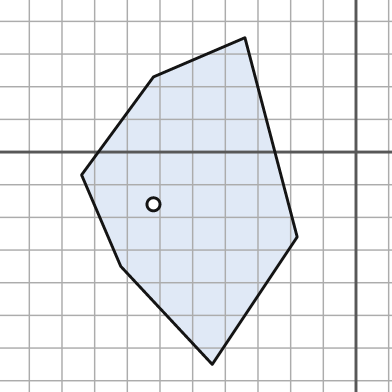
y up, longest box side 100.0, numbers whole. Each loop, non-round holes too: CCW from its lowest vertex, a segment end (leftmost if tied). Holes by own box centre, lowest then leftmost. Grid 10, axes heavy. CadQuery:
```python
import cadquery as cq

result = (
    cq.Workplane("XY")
    .moveTo(-44.0, -65.0)
    .lineTo(-18.0, -26.0)
    .lineTo(-34.0, 35.0)
    .lineTo(-62.0, 23.0)
    .lineTo(-84.0, -7.0)
    .lineTo(-72.0, -35.0)
    .close()
    .moveTo(-62.0, -16.0)
    .circle(2.0)
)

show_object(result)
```